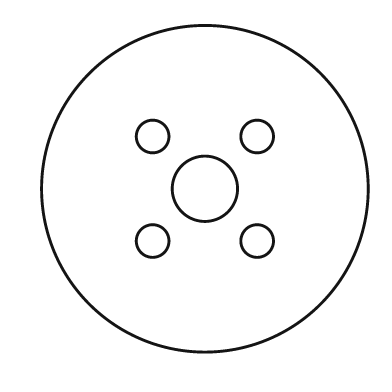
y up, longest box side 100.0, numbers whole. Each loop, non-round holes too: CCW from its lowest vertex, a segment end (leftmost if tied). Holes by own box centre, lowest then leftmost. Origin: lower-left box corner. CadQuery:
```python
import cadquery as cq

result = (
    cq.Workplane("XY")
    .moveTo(50.0, 50.0)
    .circle(50.0)
    .moveTo(34.0, 34.0)
    .circle(5.0)
    .moveTo(66.0, 34.0)
    .circle(5.0)
    .moveTo(50.0, 50.0)
    .circle(10.0)
    .moveTo(34.0, 66.0)
    .circle(5.0)
    .moveTo(66.0, 66.0)
    .circle(5.0)
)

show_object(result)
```